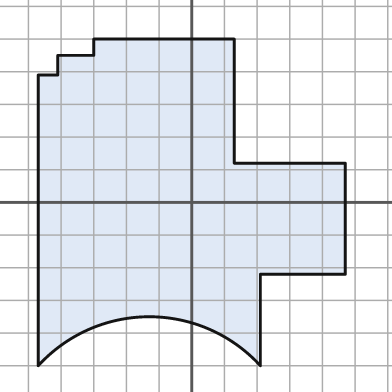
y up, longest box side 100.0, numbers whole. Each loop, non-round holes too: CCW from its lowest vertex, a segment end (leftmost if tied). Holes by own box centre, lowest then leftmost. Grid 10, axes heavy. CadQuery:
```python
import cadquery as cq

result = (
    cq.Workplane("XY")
    .moveTo(-47.0, -50.0)
    .threePointArc((-13.0, -35.0), (21.0, -50.0))
    .lineTo(21.0, -22.0)
    .lineTo(47.0, -22.0)
    .lineTo(47.0, 12.0)
    .lineTo(13.0, 12.0)
    .lineTo(13.0, 50.0)
    .lineTo(-30.0, 50.0)
    .lineTo(-30.0, 45.0)
    .lineTo(-41.0, 45.0)
    .lineTo(-41.0, 39.0)
    .lineTo(-47.0, 39.0)
    .close()
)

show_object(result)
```